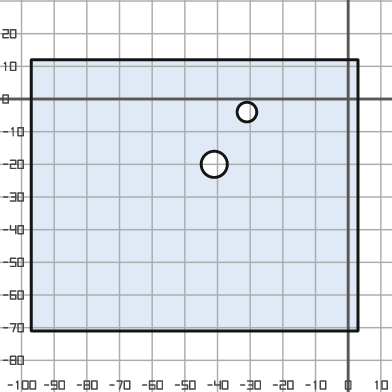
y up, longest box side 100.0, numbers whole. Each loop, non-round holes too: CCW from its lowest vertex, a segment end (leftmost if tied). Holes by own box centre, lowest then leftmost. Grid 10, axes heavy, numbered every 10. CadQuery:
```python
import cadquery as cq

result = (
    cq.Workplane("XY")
    .moveTo(-97.0, -71.0)
    .lineTo(3.0, -71.0)
    .lineTo(3.0, 12.0)
    .lineTo(-97.0, 12.0)
    .close()
    .moveTo(-41.0, -20.0)
    .circle(4.0)
    .moveTo(-31.0, -4.0)
    .circle(3.0)
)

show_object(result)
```